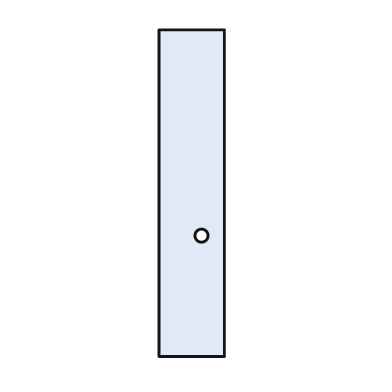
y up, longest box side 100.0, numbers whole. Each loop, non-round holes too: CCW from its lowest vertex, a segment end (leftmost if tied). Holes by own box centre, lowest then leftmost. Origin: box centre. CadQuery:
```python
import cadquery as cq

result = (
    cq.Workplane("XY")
    .moveTo(-10.0, -50.0)
    .lineTo(10.0, -50.0)
    .lineTo(10.0, 50.0)
    .lineTo(-10.0, 50.0)
    .close()
    .moveTo(3.0, -13.0)
    .circle(2.0)
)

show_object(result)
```